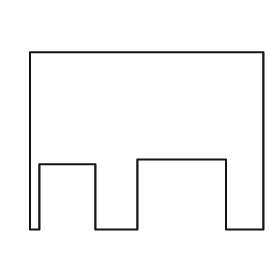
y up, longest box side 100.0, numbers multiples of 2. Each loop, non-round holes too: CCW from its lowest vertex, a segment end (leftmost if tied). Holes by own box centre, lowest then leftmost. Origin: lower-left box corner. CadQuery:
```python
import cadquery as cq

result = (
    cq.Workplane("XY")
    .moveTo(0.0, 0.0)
    .lineTo(4.0, 0.0)
    .lineTo(4.0, 28.0)
    .lineTo(28.0, 28.0)
    .lineTo(28.0, 0.0)
    .lineTo(46.0, 0.0)
    .lineTo(46.0, 30.0)
    .lineTo(84.0, 30.0)
    .lineTo(84.0, 0.0)
    .lineTo(100.0, 0.0)
    .lineTo(100.0, 76.0)
    .lineTo(0.0, 76.0)
    .close()
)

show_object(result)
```